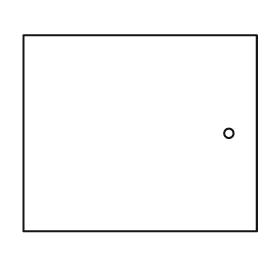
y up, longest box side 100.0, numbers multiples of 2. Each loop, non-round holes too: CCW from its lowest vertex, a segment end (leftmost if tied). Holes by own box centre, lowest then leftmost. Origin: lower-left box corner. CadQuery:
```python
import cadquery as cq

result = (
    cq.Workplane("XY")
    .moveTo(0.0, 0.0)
    .lineTo(100.0, 0.0)
    .lineTo(100.0, 84.0)
    .lineTo(0.0, 84.0)
    .close()
    .moveTo(88.0, 42.0)
    .circle(2.0)
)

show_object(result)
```